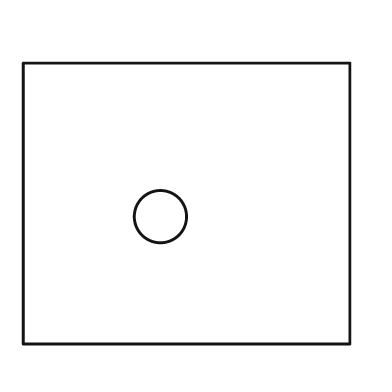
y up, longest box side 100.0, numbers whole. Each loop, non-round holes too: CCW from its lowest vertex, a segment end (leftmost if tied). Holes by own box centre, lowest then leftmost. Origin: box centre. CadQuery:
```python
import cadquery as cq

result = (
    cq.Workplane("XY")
    .moveTo(-50.0, -43.0)
    .lineTo(50.0, -43.0)
    .lineTo(50.0, 43.0)
    .lineTo(-50.0, 43.0)
    .close()
    .moveTo(-8.0, -4.0)
    .circle(8.0)
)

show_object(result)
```